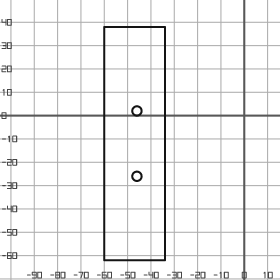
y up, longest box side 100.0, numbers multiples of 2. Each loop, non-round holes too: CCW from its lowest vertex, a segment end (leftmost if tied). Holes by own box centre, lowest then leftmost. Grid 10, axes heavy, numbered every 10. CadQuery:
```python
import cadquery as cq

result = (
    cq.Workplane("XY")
    .moveTo(-60.0, -62.0)
    .lineTo(-34.0, -62.0)
    .lineTo(-34.0, 38.0)
    .lineTo(-60.0, 38.0)
    .close()
    .moveTo(-46.0, -26.0)
    .circle(2.0)
    .moveTo(-46.0, 2.0)
    .circle(2.0)
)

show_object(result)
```